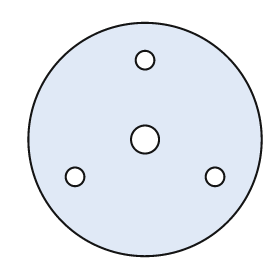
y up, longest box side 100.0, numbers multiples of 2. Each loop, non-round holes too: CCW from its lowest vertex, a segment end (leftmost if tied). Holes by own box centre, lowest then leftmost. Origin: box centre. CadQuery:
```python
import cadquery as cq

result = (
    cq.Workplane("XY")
    .moveTo(0.0, 0.0)
    .circle(50.0)
    .moveTo(-30.0, -16.0)
    .circle(4.0)
    .moveTo(30.0, -16.0)
    .circle(4.0)
    .moveTo(0.0, 0.0)
    .circle(6.0)
    .moveTo(0.0, 34.0)
    .circle(4.0)
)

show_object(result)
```